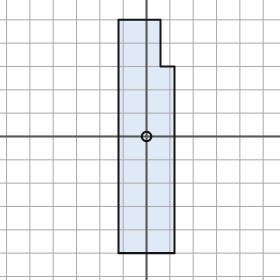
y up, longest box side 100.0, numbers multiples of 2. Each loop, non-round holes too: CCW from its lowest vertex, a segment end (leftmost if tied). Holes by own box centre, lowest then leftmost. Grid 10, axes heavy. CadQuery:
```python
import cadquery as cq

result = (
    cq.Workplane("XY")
    .moveTo(-12.0, -50.0)
    .lineTo(12.0, -50.0)
    .lineTo(12.0, 30.0)
    .lineTo(6.0, 30.0)
    .lineTo(6.0, 50.0)
    .lineTo(-12.0, 50.0)
    .close()
    .moveTo(0.0, 0.0)
    .circle(2.0)
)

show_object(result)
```